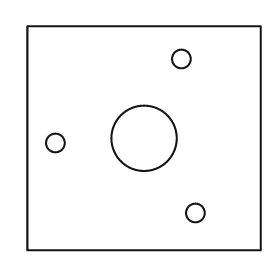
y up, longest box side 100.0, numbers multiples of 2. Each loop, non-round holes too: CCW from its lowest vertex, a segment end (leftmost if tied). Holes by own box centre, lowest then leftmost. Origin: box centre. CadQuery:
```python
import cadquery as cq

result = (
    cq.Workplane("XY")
    .moveTo(-50.0, -48.0)
    .lineTo(50.0, -48.0)
    .lineTo(50.0, 48.0)
    .lineTo(-50.0, 48.0)
    .close()
    .moveTo(22.0, -32.0)
    .circle(4.0)
    .moveTo(-38.0, -2.0)
    .circle(4.0)
    .moveTo(0.0, 0.0)
    .circle(14.0)
    .moveTo(16.0, 34.0)
    .circle(4.0)
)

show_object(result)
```